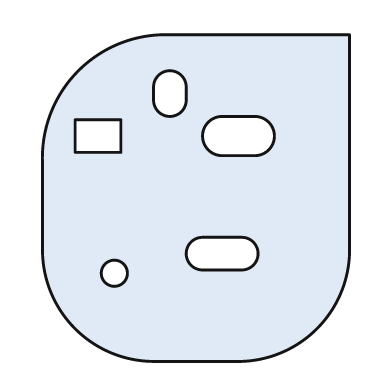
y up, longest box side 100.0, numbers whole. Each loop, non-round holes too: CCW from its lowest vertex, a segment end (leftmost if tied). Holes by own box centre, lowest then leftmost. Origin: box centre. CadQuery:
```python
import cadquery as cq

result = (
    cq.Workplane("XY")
    .moveTo(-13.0, -50.0)
    .lineTo(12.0, -50.0)
    .threePointArc((37.0, -40.0), (47.0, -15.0))
    .lineTo(47.0, 50.0)
    .lineTo(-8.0, 50.0)
    .threePointArc((-36.0, 39.0), (-47.0, 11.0))
    .lineTo(-47.0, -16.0)
    .threePointArc((-37.0, -40.0), (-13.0, -50.0))
    .close()
    .moveTo(-25.0, -23.0)
    .circle(4.0)
    .moveTo(2.0, -22.0)
    .lineTo(14.0, -22.0)
    .threePointArc((19.0, -17.0), (14.0, -12.0))
    .lineTo(2.0, -12.0)
    .threePointArc((-3.0, -17.0), (2.0, -22.0))
    .close()
    .moveTo(-37.0, 14.0)
    .lineTo(-23.0, 14.0)
    .lineTo(-23.0, 24.0)
    .lineTo(-37.0, 24.0)
    .close()
    .moveTo(8.0, 13.0)
    .lineTo(18.0, 13.0)
    .threePointArc((24.0, 19.0), (18.0, 25.0))
    .lineTo(8.0, 25.0)
    .threePointArc((2.0, 19.0), (8.0, 13.0))
    .close()
    .moveTo(-13.0, 30.0)
    .threePointArc((-8.0, 25.0), (-3.0, 30.0))
    .lineTo(-3.0, 34.0)
    .threePointArc((-8.0, 39.0), (-13.0, 34.0))
    .close()
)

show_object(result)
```